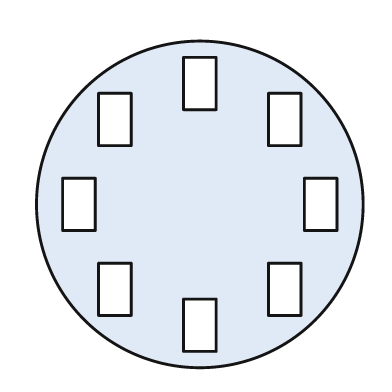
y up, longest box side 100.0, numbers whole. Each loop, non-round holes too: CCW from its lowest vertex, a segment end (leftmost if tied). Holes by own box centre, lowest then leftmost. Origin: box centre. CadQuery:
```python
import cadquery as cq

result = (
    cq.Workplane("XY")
    .moveTo(0.0, 0.0)
    .circle(50.0)
    .moveTo(-5.0, -45.0)
    .lineTo(5.0, -45.0)
    .lineTo(5.0, -29.0)
    .lineTo(-5.0, -29.0)
    .close()
    .moveTo(-31.0, -34.0)
    .lineTo(-21.0, -34.0)
    .lineTo(-21.0, -18.0)
    .lineTo(-31.0, -18.0)
    .close()
    .moveTo(21.0, -34.0)
    .lineTo(31.0, -34.0)
    .lineTo(31.0, -18.0)
    .lineTo(21.0, -18.0)
    .close()
    .moveTo(-42.0, -8.0)
    .lineTo(-32.0, -8.0)
    .lineTo(-32.0, 8.0)
    .lineTo(-42.0, 8.0)
    .close()
    .moveTo(32.0, -8.0)
    .lineTo(42.0, -8.0)
    .lineTo(42.0, 8.0)
    .lineTo(32.0, 8.0)
    .close()
    .moveTo(-31.0, 18.0)
    .lineTo(-21.0, 18.0)
    .lineTo(-21.0, 34.0)
    .lineTo(-31.0, 34.0)
    .close()
    .moveTo(21.0, 18.0)
    .lineTo(31.0, 18.0)
    .lineTo(31.0, 34.0)
    .lineTo(21.0, 34.0)
    .close()
    .moveTo(-5.0, 29.0)
    .lineTo(5.0, 29.0)
    .lineTo(5.0, 45.0)
    .lineTo(-5.0, 45.0)
    .close()
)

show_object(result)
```